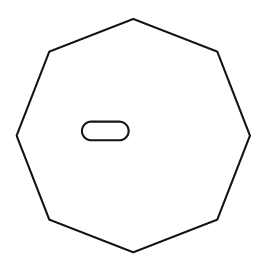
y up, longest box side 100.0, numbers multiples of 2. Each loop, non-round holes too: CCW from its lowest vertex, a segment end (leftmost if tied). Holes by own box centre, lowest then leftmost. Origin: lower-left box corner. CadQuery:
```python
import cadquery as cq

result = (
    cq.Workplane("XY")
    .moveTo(50.0, 0.0)
    .lineTo(86.0, 14.0)
    .lineTo(100.0, 50.0)
    .lineTo(86.0, 86.0)
    .lineTo(50.0, 100.0)
    .lineTo(14.0, 86.0)
    .lineTo(0.0, 50.0)
    .lineTo(14.0, 14.0)
    .close()
    .moveTo(32.0, 48.0)
    .lineTo(44.0, 48.0)
    .threePointArc((48.0, 52.0), (44.0, 56.0))
    .lineTo(32.0, 56.0)
    .threePointArc((28.0, 52.0), (32.0, 48.0))
    .close()
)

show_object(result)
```